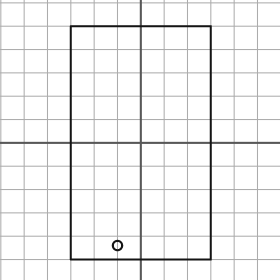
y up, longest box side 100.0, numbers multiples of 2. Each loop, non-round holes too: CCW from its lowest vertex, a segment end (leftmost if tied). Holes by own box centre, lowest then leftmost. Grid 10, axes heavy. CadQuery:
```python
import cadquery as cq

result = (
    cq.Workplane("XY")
    .moveTo(-30.0, -50.0)
    .lineTo(30.0, -50.0)
    .lineTo(30.0, 50.0)
    .lineTo(-30.0, 50.0)
    .close()
    .moveTo(-10.0, -44.0)
    .circle(2.0)
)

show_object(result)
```